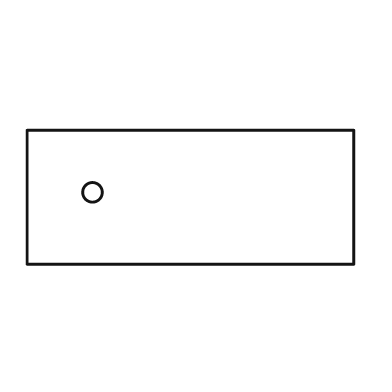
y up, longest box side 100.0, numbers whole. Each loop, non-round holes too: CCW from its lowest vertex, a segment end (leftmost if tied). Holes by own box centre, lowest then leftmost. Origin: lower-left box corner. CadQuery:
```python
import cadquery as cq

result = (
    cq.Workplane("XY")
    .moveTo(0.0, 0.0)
    .lineTo(100.0, 0.0)
    .lineTo(100.0, 41.0)
    .lineTo(0.0, 41.0)
    .close()
    .moveTo(20.0, 22.0)
    .circle(3.0)
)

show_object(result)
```